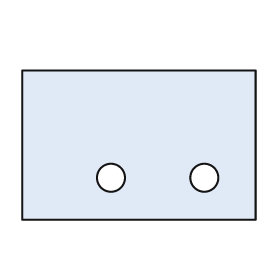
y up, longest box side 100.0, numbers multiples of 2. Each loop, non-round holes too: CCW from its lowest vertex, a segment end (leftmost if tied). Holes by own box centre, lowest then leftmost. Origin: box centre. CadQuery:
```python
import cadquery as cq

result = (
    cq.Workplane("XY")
    .moveTo(-50.0, -32.0)
    .lineTo(50.0, -32.0)
    .lineTo(50.0, 32.0)
    .lineTo(-50.0, 32.0)
    .close()
    .moveTo(-12.0, -14.0)
    .circle(6.0)
    .moveTo(28.0, -14.0)
    .circle(6.0)
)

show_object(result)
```